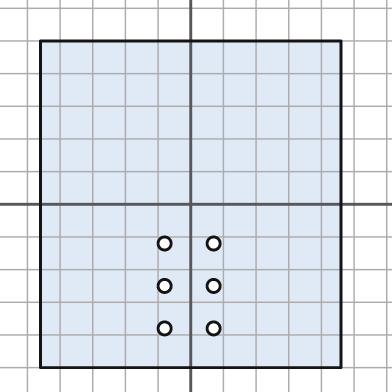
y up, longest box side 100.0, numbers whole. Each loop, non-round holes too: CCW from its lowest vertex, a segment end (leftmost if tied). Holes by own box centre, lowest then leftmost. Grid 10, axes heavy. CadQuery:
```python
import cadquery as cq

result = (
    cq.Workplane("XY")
    .moveTo(-46.0, -50.0)
    .lineTo(46.0, -50.0)
    .lineTo(46.0, 50.0)
    .lineTo(-46.0, 50.0)
    .close()
    .moveTo(-8.0, -38.0)
    .circle(2.0)
    .moveTo(7.0, -38.0)
    .circle(2.0)
    .moveTo(-8.0, -25.0)
    .circle(2.0)
    .moveTo(7.0, -25.0)
    .circle(2.0)
    .moveTo(-8.0, -12.0)
    .circle(2.0)
    .moveTo(7.0, -12.0)
    .circle(2.0)
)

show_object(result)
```